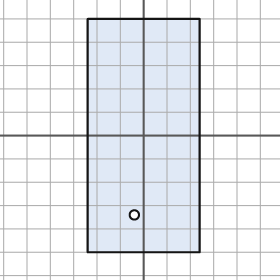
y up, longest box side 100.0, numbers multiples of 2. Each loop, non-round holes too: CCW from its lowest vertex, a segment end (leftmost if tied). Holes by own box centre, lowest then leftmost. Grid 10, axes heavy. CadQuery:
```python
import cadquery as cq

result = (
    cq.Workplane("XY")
    .moveTo(-24.0, -50.0)
    .lineTo(24.0, -50.0)
    .lineTo(24.0, 50.0)
    .lineTo(-24.0, 50.0)
    .close()
    .moveTo(-4.0, -34.0)
    .circle(2.0)
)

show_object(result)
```